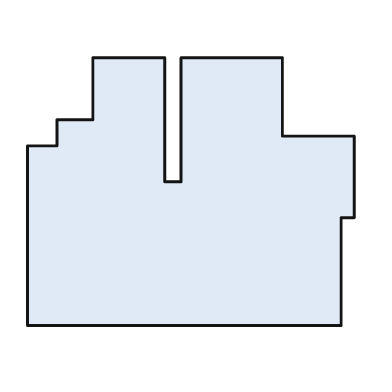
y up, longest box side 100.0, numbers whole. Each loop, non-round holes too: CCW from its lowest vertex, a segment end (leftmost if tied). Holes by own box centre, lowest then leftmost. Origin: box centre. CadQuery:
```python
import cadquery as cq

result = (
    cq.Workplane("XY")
    .moveTo(-50.0, -41.0)
    .lineTo(46.0, -41.0)
    .lineTo(46.0, -8.0)
    .lineTo(50.0, -8.0)
    .lineTo(50.0, 17.0)
    .lineTo(28.0, 17.0)
    .lineTo(28.0, 41.0)
    .lineTo(-3.0, 41.0)
    .lineTo(-3.0, 3.0)
    .lineTo(-8.0, 3.0)
    .lineTo(-8.0, 41.0)
    .lineTo(-30.0, 41.0)
    .lineTo(-30.0, 22.0)
    .lineTo(-41.0, 22.0)
    .lineTo(-41.0, 14.0)
    .lineTo(-50.0, 14.0)
    .close()
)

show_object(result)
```